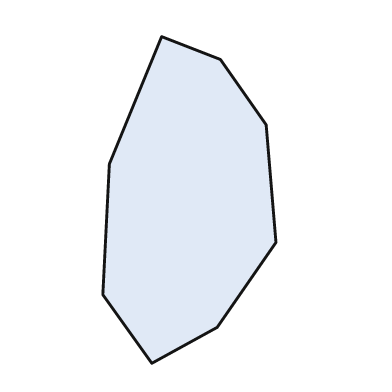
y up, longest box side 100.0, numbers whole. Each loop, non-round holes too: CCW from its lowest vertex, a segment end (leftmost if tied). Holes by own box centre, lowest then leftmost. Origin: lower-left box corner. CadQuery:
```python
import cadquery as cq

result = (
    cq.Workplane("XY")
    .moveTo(15.0, 0.0)
    .lineTo(35.0, 11.0)
    .lineTo(53.0, 37.0)
    .lineTo(50.0, 73.0)
    .lineTo(36.0, 93.0)
    .lineTo(18.0, 100.0)
    .lineTo(2.0, 61.0)
    .lineTo(0.0, 21.0)
    .close()
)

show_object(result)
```